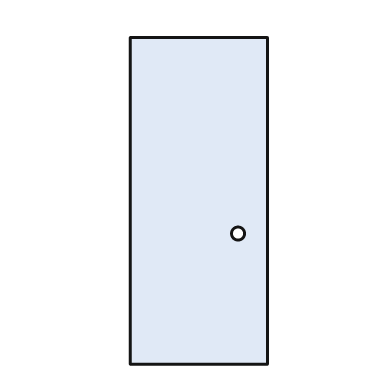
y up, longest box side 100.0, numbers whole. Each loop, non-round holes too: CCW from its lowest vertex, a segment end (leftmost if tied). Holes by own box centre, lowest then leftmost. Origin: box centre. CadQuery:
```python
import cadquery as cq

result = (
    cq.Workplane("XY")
    .moveTo(-21.0, -50.0)
    .lineTo(21.0, -50.0)
    .lineTo(21.0, 50.0)
    .lineTo(-21.0, 50.0)
    .close()
    .moveTo(12.0, -10.0)
    .circle(2.0)
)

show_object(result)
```